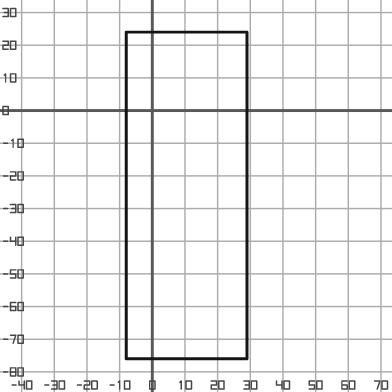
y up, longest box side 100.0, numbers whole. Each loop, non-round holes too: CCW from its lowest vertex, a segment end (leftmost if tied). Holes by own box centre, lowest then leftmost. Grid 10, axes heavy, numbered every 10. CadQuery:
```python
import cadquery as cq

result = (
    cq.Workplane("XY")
    .moveTo(-8.0, -76.0)
    .lineTo(29.0, -76.0)
    .lineTo(29.0, 24.0)
    .lineTo(-8.0, 24.0)
    .close()
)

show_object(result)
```